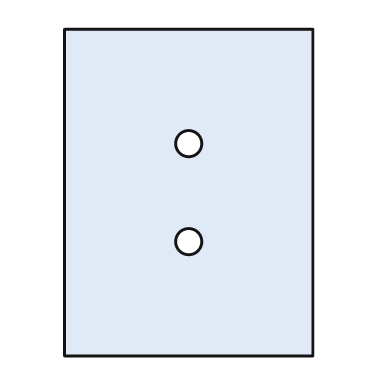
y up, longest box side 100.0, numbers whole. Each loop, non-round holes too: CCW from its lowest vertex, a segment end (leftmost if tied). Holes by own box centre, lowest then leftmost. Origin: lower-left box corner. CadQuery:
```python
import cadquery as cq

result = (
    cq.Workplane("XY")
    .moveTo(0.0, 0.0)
    .lineTo(76.0, 0.0)
    .lineTo(76.0, 100.0)
    .lineTo(0.0, 100.0)
    .close()
    .moveTo(38.0, 35.0)
    .circle(4.0)
    .moveTo(38.0, 65.0)
    .circle(4.0)
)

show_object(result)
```